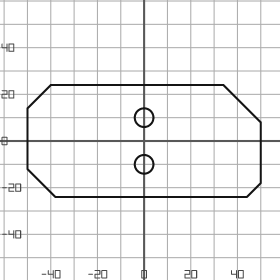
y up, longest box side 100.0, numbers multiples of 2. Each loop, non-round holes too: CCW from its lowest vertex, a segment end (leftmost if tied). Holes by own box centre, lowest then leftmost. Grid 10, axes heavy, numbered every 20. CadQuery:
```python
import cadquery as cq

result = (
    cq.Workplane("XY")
    .moveTo(-38.0, -24.0)
    .lineTo(44.0, -24.0)
    .lineTo(50.0, -18.0)
    .lineTo(50.0, 8.0)
    .lineTo(34.0, 24.0)
    .lineTo(-40.0, 24.0)
    .lineTo(-50.0, 14.0)
    .lineTo(-50.0, -12.0)
    .close()
    .moveTo(0.0, -10.0)
    .circle(4.0)
    .moveTo(0.0, 10.0)
    .circle(4.0)
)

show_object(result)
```